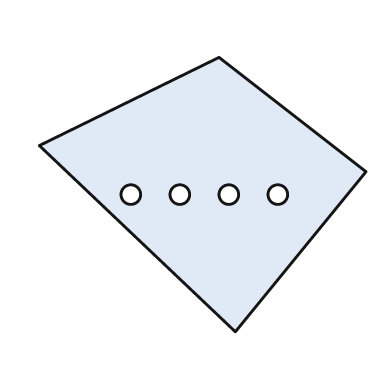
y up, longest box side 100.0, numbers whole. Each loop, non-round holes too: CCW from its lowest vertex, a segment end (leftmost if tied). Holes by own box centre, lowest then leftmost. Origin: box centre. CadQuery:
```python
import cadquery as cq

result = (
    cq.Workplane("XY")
    .moveTo(10.0, -42.0)
    .lineTo(50.0, 7.0)
    .lineTo(5.0, 42.0)
    .lineTo(-50.0, 15.0)
    .close()
    .moveTo(-22.0, 0.0)
    .circle(3.0)
    .moveTo(-7.0, 0.0)
    .circle(3.0)
    .moveTo(8.0, 0.0)
    .circle(3.0)
    .moveTo(23.0, 0.0)
    .circle(3.0)
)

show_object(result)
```